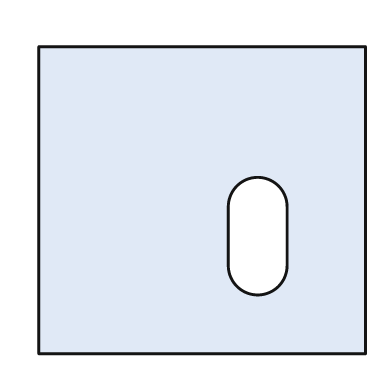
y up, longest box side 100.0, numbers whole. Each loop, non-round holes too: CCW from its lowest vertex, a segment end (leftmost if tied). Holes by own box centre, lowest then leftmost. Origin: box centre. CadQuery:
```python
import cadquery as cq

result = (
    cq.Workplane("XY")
    .moveTo(-50.0, -47.0)
    .lineTo(50.0, -47.0)
    .lineTo(50.0, 47.0)
    .lineTo(-50.0, 47.0)
    .close()
    .moveTo(8.0, -20.0)
    .threePointArc((17.0, -29.0), (26.0, -20.0))
    .lineTo(26.0, -2.0)
    .threePointArc((17.0, 7.0), (8.0, -2.0))
    .close()
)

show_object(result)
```